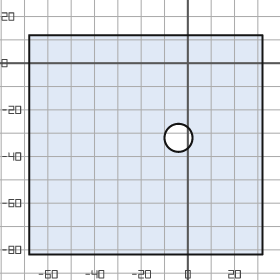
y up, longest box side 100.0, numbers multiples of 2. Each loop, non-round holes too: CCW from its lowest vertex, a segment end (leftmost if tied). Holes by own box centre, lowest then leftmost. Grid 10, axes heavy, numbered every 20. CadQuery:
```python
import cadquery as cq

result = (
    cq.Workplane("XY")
    .moveTo(-68.0, -82.0)
    .lineTo(32.0, -82.0)
    .lineTo(32.0, 12.0)
    .lineTo(-68.0, 12.0)
    .close()
    .moveTo(-4.0, -32.0)
    .circle(6.0)
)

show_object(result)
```